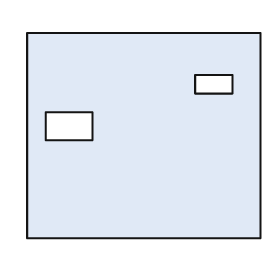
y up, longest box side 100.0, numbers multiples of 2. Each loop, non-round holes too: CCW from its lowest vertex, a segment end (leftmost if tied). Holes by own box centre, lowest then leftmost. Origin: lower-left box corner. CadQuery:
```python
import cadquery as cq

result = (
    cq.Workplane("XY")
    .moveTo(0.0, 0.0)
    .lineTo(100.0, 0.0)
    .lineTo(100.0, 88.0)
    .lineTo(0.0, 88.0)
    .close()
    .moveTo(8.0, 42.0)
    .lineTo(28.0, 42.0)
    .lineTo(28.0, 54.0)
    .lineTo(8.0, 54.0)
    .close()
    .moveTo(72.0, 62.0)
    .lineTo(88.0, 62.0)
    .lineTo(88.0, 70.0)
    .lineTo(72.0, 70.0)
    .close()
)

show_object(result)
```